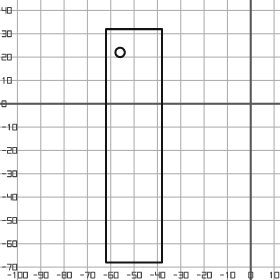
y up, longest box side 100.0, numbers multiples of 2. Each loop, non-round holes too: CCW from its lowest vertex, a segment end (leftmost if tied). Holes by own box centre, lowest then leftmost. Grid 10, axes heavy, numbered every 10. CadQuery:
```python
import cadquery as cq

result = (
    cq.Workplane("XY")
    .moveTo(-62.0, -68.0)
    .lineTo(-38.0, -68.0)
    .lineTo(-38.0, 32.0)
    .lineTo(-62.0, 32.0)
    .close()
    .moveTo(-56.0, 22.0)
    .circle(2.0)
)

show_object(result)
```